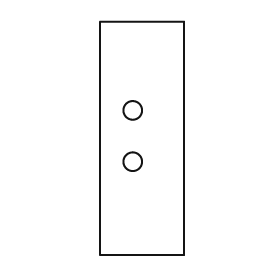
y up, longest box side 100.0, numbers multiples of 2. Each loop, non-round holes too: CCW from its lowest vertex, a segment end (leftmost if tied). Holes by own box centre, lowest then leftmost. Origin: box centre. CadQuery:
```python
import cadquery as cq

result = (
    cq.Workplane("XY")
    .moveTo(-18.0, -50.0)
    .lineTo(18.0, -50.0)
    .lineTo(18.0, 50.0)
    .lineTo(-18.0, 50.0)
    .close()
    .moveTo(-4.0, -10.0)
    .circle(4.0)
    .moveTo(-4.0, 12.0)
    .circle(4.0)
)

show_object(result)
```